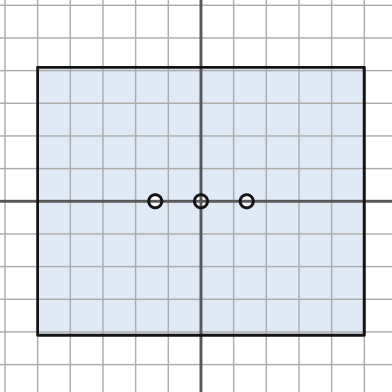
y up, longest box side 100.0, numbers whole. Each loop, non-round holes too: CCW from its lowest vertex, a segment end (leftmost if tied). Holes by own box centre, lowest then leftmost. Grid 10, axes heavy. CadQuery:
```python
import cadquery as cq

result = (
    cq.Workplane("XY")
    .moveTo(-50.0, -41.0)
    .lineTo(50.0, -41.0)
    .lineTo(50.0, 41.0)
    .lineTo(-50.0, 41.0)
    .close()
    .moveTo(-14.0, 0.0)
    .circle(2.0)
    .moveTo(0.0, 0.0)
    .circle(2.0)
    .moveTo(14.0, 0.0)
    .circle(2.0)
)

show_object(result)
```